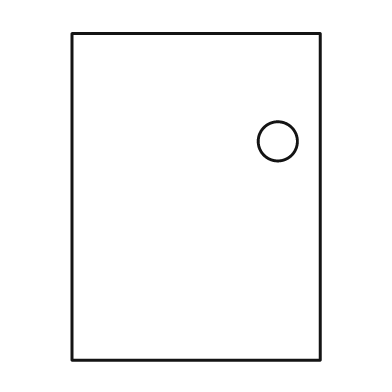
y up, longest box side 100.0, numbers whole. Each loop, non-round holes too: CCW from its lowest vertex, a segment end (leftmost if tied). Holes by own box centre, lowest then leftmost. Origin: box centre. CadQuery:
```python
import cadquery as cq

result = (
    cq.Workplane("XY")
    .moveTo(-38.0, -50.0)
    .lineTo(38.0, -50.0)
    .lineTo(38.0, 50.0)
    .lineTo(-38.0, 50.0)
    .close()
    .moveTo(25.0, 17.0)
    .circle(6.0)
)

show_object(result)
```